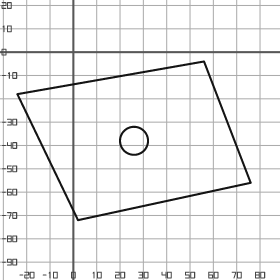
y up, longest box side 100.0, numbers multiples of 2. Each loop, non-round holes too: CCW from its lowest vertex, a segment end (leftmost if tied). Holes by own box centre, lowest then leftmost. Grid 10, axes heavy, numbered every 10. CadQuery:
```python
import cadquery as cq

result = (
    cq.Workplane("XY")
    .moveTo(2.0, -72.0)
    .lineTo(76.0, -56.0)
    .lineTo(56.0, -4.0)
    .lineTo(-24.0, -18.0)
    .close()
    .moveTo(26.0, -38.0)
    .circle(6.0)
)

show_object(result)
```